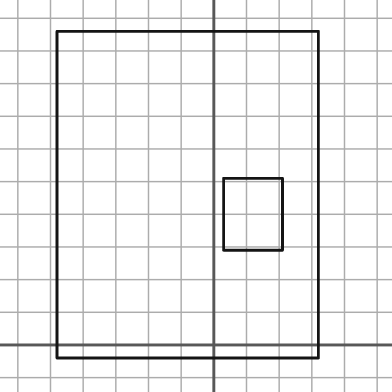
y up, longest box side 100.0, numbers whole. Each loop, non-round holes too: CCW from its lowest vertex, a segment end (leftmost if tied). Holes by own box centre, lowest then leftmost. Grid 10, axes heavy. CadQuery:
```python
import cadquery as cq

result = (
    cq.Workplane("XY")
    .moveTo(-48.0, -4.0)
    .lineTo(32.0, -4.0)
    .lineTo(32.0, 96.0)
    .lineTo(-48.0, 96.0)
    .close()
    .moveTo(3.0, 29.0)
    .lineTo(21.0, 29.0)
    .lineTo(21.0, 51.0)
    .lineTo(3.0, 51.0)
    .close()
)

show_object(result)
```